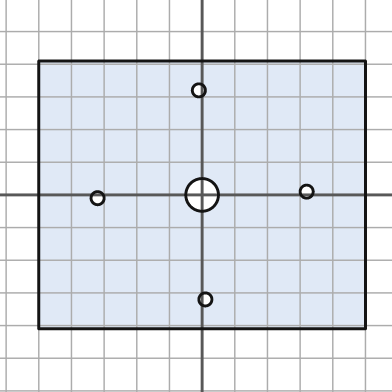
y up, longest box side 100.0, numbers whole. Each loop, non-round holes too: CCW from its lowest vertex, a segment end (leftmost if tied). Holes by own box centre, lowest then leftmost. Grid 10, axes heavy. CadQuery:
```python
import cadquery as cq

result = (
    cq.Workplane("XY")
    .moveTo(-50.0, -41.0)
    .lineTo(50.0, -41.0)
    .lineTo(50.0, 41.0)
    .lineTo(-50.0, 41.0)
    .close()
    .moveTo(1.0, -32.0)
    .circle(2.0)
    .moveTo(-32.0, -1.0)
    .circle(2.0)
    .moveTo(0.0, 0.0)
    .circle(5.0)
    .moveTo(32.0, 1.0)
    .circle(2.0)
    .moveTo(-1.0, 32.0)
    .circle(2.0)
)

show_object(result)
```